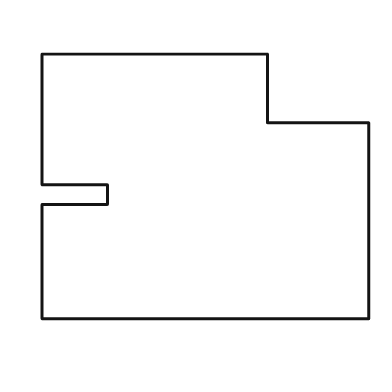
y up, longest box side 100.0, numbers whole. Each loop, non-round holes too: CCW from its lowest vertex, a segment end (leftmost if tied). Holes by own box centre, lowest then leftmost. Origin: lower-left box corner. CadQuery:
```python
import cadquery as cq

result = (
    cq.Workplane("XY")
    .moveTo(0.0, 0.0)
    .lineTo(100.0, 0.0)
    .lineTo(100.0, 60.0)
    .lineTo(69.0, 60.0)
    .lineTo(69.0, 81.0)
    .lineTo(0.0, 81.0)
    .lineTo(0.0, 41.0)
    .lineTo(20.0, 41.0)
    .lineTo(20.0, 35.0)
    .lineTo(0.0, 35.0)
    .close()
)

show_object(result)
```